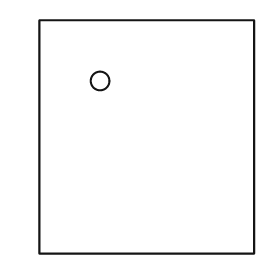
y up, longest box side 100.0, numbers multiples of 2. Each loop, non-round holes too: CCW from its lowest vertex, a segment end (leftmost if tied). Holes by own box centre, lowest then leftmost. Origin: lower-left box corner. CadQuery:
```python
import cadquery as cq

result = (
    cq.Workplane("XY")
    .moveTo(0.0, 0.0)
    .lineTo(92.0, 0.0)
    .lineTo(92.0, 100.0)
    .lineTo(0.0, 100.0)
    .close()
    .moveTo(26.0, 74.0)
    .circle(4.0)
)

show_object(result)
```